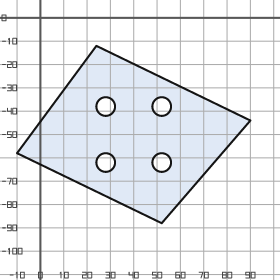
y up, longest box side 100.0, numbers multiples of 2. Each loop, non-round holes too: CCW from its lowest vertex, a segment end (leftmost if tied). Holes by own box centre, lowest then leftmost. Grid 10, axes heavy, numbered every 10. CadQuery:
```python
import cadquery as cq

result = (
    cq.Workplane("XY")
    .moveTo(52.0, -88.0)
    .lineTo(90.0, -44.0)
    .lineTo(24.0, -12.0)
    .lineTo(-10.0, -58.0)
    .close()
    .moveTo(28.0, -62.0)
    .circle(4.0)
    .moveTo(52.0, -62.0)
    .circle(4.0)
    .moveTo(28.0, -38.0)
    .circle(4.0)
    .moveTo(52.0, -38.0)
    .circle(4.0)
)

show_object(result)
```